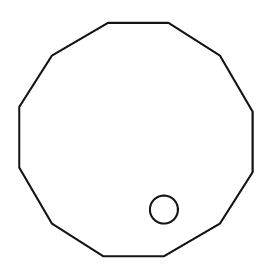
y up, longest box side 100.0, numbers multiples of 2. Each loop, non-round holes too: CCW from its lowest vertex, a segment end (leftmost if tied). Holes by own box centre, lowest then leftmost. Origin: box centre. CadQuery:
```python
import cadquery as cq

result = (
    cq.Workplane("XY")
    .moveTo(-14.0, -50.0)
    .lineTo(12.0, -50.0)
    .lineTo(36.0, -36.0)
    .lineTo(50.0, -14.0)
    .lineTo(50.0, 12.0)
    .lineTo(36.0, 36.0)
    .lineTo(14.0, 50.0)
    .lineTo(-12.0, 50.0)
    .lineTo(-36.0, 36.0)
    .lineTo(-50.0, 14.0)
    .lineTo(-50.0, -12.0)
    .lineTo(-36.0, -36.0)
    .close()
    .moveTo(12.0, -30.0)
    .circle(6.0)
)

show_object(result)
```